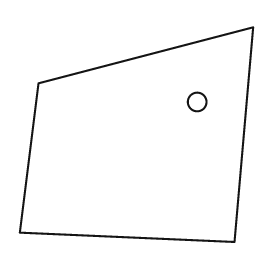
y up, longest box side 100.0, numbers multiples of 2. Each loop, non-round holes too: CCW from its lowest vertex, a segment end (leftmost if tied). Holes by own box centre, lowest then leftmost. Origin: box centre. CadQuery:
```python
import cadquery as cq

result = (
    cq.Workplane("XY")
    .moveTo(42.0, -46.0)
    .lineTo(50.0, 46.0)
    .lineTo(-42.0, 22.0)
    .lineTo(-50.0, -42.0)
    .close()
    .moveTo(26.0, 14.0)
    .circle(4.0)
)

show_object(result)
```